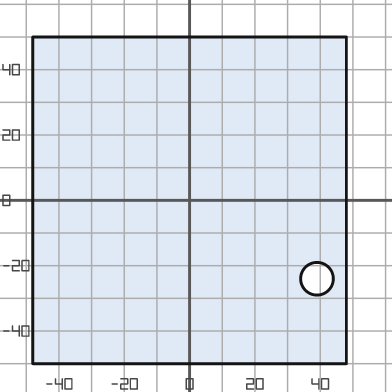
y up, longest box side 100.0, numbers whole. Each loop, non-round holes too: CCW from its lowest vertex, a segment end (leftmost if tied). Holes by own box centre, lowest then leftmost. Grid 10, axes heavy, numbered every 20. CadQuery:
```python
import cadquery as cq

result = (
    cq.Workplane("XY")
    .moveTo(-48.0, -50.0)
    .lineTo(48.0, -50.0)
    .lineTo(48.0, 50.0)
    .lineTo(-48.0, 50.0)
    .close()
    .moveTo(39.0, -24.0)
    .circle(5.0)
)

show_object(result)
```